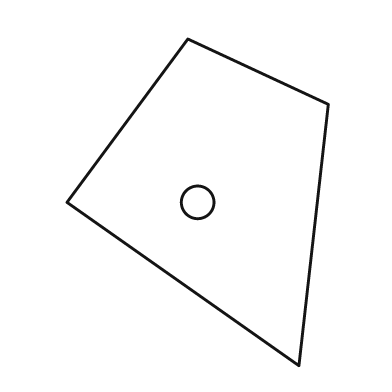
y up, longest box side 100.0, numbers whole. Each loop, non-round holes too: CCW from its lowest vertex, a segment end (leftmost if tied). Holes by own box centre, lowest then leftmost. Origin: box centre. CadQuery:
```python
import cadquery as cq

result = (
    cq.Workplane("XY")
    .moveTo(31.0, -50.0)
    .lineTo(40.0, 30.0)
    .lineTo(-3.0, 50.0)
    .lineTo(-40.0, 0.0)
    .close()
    .moveTo(0.0, 0.0)
    .circle(5.0)
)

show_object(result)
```